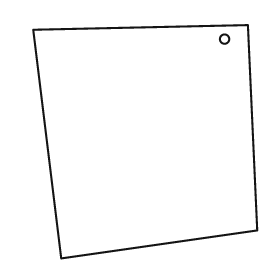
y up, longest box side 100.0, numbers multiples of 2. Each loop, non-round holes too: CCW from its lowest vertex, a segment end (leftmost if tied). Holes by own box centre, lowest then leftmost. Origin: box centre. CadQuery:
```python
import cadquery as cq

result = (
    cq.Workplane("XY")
    .moveTo(-36.0, -50.0)
    .lineTo(48.0, -38.0)
    .lineTo(44.0, 50.0)
    .lineTo(-48.0, 48.0)
    .close()
    .moveTo(34.0, 44.0)
    .circle(2.0)
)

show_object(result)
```